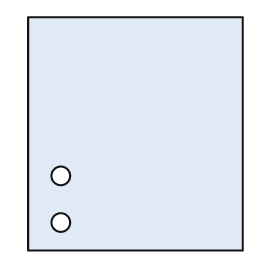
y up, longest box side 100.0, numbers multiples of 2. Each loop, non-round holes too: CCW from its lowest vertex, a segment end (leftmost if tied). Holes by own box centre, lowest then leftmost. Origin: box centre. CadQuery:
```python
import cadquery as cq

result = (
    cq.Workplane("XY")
    .moveTo(-46.0, -50.0)
    .lineTo(46.0, -50.0)
    .lineTo(46.0, 50.0)
    .lineTo(-46.0, 50.0)
    .close()
    .moveTo(-32.0, -38.0)
    .circle(4.0)
    .moveTo(-32.0, -18.0)
    .circle(4.0)
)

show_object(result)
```